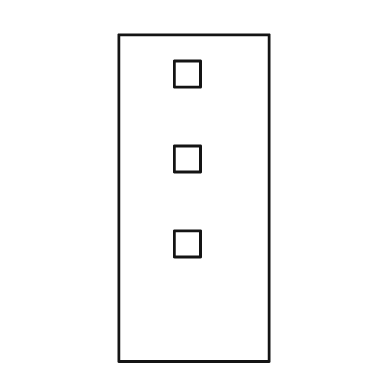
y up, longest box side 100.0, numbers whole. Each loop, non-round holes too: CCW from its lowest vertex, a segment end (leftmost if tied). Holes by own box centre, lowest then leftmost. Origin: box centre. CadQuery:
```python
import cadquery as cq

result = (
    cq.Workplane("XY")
    .moveTo(-23.0, -50.0)
    .lineTo(23.0, -50.0)
    .lineTo(23.0, 50.0)
    .lineTo(-23.0, 50.0)
    .close()
    .moveTo(-6.0, -18.0)
    .lineTo(2.0, -18.0)
    .lineTo(2.0, -10.0)
    .lineTo(-6.0, -10.0)
    .close()
    .moveTo(-6.0, 8.0)
    .lineTo(2.0, 8.0)
    .lineTo(2.0, 16.0)
    .lineTo(-6.0, 16.0)
    .close()
    .moveTo(-6.0, 34.0)
    .lineTo(2.0, 34.0)
    .lineTo(2.0, 42.0)
    .lineTo(-6.0, 42.0)
    .close()
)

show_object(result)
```